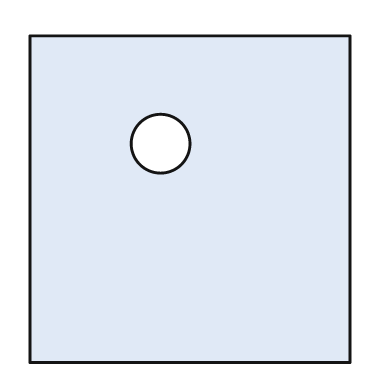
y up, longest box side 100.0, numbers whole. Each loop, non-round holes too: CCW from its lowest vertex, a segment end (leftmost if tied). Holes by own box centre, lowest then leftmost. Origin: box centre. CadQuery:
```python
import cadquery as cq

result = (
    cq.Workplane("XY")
    .moveTo(-49.0, -50.0)
    .lineTo(49.0, -50.0)
    .lineTo(49.0, 50.0)
    .lineTo(-49.0, 50.0)
    .close()
    .moveTo(-9.0, 17.0)
    .circle(9.0)
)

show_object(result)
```